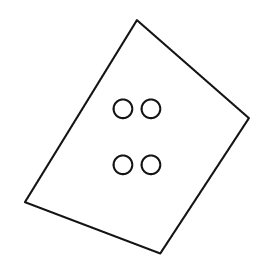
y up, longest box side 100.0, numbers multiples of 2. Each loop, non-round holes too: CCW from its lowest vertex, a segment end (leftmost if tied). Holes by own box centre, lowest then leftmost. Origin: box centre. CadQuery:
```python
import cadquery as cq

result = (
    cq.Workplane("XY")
    .moveTo(10.0, -50.0)
    .lineTo(48.0, 8.0)
    .lineTo(0.0, 50.0)
    .lineTo(-48.0, -28.0)
    .close()
    .moveTo(-6.0, -12.0)
    .circle(4.0)
    .moveTo(6.0, -12.0)
    .circle(4.0)
    .moveTo(-6.0, 12.0)
    .circle(4.0)
    .moveTo(6.0, 12.0)
    .circle(4.0)
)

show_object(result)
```